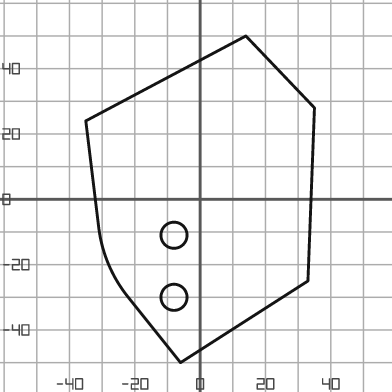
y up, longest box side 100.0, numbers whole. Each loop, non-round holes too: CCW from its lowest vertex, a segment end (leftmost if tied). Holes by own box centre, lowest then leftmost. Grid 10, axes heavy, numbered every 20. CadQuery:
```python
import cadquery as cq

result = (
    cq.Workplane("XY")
    .moveTo(-6.0, -50.0)
    .lineTo(33.0, -25.0)
    .lineTo(35.0, 28.0)
    .lineTo(14.0, 50.0)
    .lineTo(-35.0, 24.0)
    .lineTo(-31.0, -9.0)
    .threePointArc((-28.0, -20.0), (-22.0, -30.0))
    .close()
    .moveTo(-8.0, -30.0)
    .circle(4.0)
    .moveTo(-8.0, -11.0)
    .circle(4.0)
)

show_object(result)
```